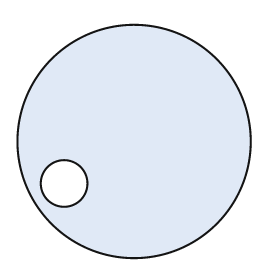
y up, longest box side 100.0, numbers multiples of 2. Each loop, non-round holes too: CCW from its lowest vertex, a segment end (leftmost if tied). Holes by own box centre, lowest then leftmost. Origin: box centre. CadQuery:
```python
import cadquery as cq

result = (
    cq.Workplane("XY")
    .moveTo(0.0, 0.0)
    .circle(50.0)
    .moveTo(-30.0, -18.0)
    .circle(10.0)
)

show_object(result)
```